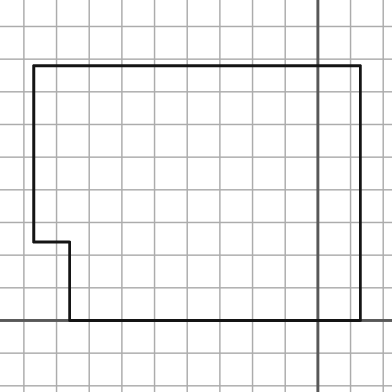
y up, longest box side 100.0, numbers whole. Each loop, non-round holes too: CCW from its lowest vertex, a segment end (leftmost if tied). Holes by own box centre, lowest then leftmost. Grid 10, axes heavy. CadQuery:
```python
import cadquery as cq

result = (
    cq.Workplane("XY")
    .moveTo(-76.0, 0.0)
    .lineTo(13.0, 0.0)
    .lineTo(13.0, 78.0)
    .lineTo(-87.0, 78.0)
    .lineTo(-87.0, 24.0)
    .lineTo(-76.0, 24.0)
    .close()
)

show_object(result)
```